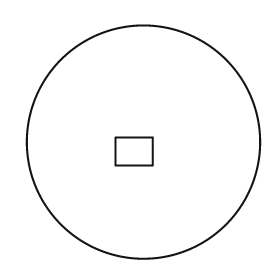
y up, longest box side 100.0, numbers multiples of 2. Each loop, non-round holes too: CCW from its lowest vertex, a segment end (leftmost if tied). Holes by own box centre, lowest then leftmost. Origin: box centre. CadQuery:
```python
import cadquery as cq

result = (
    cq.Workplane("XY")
    .moveTo(0.0, 0.0)
    .circle(50.0)
    .moveTo(-12.0, -10.0)
    .lineTo(4.0, -10.0)
    .lineTo(4.0, 2.0)
    .lineTo(-12.0, 2.0)
    .close()
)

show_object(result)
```